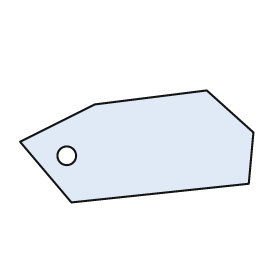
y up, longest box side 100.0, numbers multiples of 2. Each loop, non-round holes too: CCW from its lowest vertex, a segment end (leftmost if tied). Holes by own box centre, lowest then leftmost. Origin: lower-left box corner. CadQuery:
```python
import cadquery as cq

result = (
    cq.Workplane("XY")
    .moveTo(22.0, 0.0)
    .lineTo(98.0, 8.0)
    .lineTo(100.0, 30.0)
    .lineTo(80.0, 48.0)
    .lineTo(32.0, 42.0)
    .lineTo(0.0, 26.0)
    .close()
    .moveTo(20.0, 20.0)
    .circle(4.0)
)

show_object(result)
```